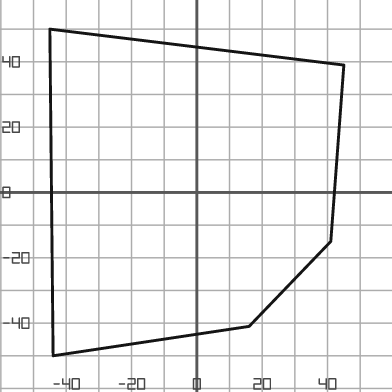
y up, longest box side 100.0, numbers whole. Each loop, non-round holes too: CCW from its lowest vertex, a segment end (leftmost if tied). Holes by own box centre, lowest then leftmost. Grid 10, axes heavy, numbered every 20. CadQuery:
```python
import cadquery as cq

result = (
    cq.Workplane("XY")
    .moveTo(-44.0, -50.0)
    .lineTo(16.0, -41.0)
    .lineTo(41.0, -15.0)
    .lineTo(45.0, 39.0)
    .lineTo(-45.0, 50.0)
    .close()
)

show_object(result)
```